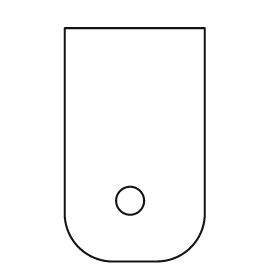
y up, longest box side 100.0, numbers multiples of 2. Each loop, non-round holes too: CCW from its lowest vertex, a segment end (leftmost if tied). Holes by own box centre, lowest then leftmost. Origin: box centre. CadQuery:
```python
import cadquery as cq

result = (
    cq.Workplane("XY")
    .moveTo(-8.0, -50.0)
    .lineTo(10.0, -50.0)
    .threePointArc((24.0, -44.0), (30.0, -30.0))
    .lineTo(30.0, 50.0)
    .lineTo(-30.0, 50.0)
    .lineTo(-30.0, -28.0)
    .threePointArc((-24.0, -44.0), (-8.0, -50.0))
    .close()
    .moveTo(-2.0, -24.0)
    .circle(6.0)
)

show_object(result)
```